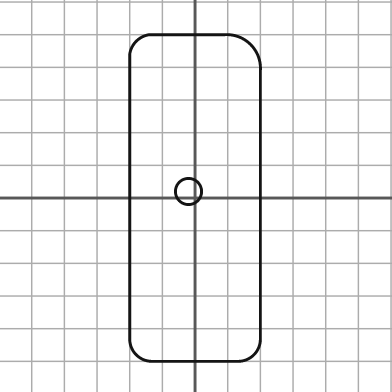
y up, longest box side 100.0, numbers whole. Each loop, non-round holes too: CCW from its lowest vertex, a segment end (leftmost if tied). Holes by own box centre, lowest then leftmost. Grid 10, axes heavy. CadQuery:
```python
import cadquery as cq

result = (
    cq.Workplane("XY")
    .moveTo(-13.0, -50.0)
    .lineTo(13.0, -50.0)
    .threePointArc((18.0, -48.0), (20.0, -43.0))
    .lineTo(20.0, 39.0)
    .threePointArc((17.0, 47.0), (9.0, 50.0))
    .lineTo(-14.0, 50.0)
    .threePointArc((-18.0, 48.0), (-20.0, 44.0))
    .lineTo(-20.0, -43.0)
    .threePointArc((-18.0, -48.0), (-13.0, -50.0))
    .close()
    .moveTo(-2.0, 2.0)
    .circle(4.0)
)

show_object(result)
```